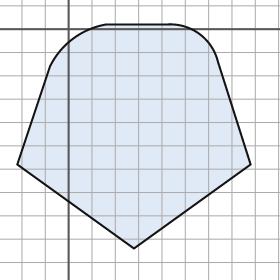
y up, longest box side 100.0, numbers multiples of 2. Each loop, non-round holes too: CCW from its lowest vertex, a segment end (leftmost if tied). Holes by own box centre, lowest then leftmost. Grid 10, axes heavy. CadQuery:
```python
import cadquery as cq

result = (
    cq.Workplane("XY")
    .moveTo(28.0, -94.0)
    .lineTo(78.0, -58.0)
    .lineTo(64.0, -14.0)
    .threePointArc((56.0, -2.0), (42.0, 2.0))
    .lineTo(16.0, 2.0)
    .threePointArc((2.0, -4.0), (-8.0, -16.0))
    .lineTo(-22.0, -58.0)
    .close()
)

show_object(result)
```